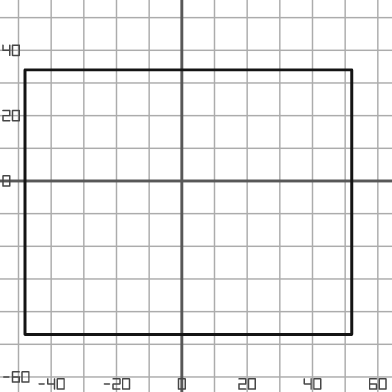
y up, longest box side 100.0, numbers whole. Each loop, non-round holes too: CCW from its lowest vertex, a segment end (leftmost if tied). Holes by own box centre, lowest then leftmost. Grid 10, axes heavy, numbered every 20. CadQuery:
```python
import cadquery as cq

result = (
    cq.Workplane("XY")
    .moveTo(-48.0, -47.0)
    .lineTo(52.0, -47.0)
    .lineTo(52.0, 34.0)
    .lineTo(-48.0, 34.0)
    .close()
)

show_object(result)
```